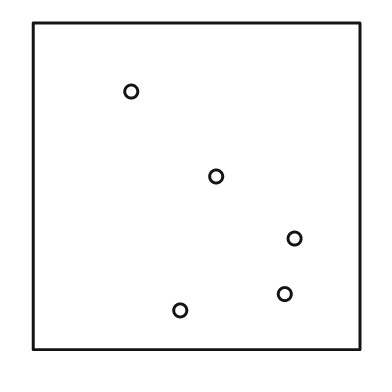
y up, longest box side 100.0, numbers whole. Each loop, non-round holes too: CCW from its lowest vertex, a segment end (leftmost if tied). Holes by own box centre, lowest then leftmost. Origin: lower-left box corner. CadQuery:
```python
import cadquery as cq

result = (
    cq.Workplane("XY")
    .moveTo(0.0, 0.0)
    .lineTo(100.0, 0.0)
    .lineTo(100.0, 100.0)
    .lineTo(0.0, 100.0)
    .close()
    .moveTo(45.0, 12.0)
    .circle(2.0)
    .moveTo(77.0, 17.0)
    .circle(2.0)
    .moveTo(80.0, 34.0)
    .circle(2.0)
    .moveTo(56.0, 53.0)
    .circle(2.0)
    .moveTo(30.0, 79.0)
    .circle(2.0)
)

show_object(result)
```